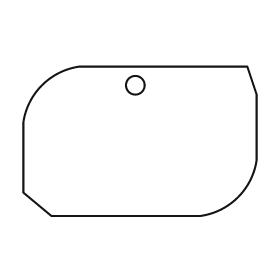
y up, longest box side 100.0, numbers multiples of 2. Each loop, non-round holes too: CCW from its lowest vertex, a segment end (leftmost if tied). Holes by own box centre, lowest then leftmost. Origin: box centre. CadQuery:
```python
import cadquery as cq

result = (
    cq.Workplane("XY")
    .moveTo(-38.0, -32.0)
    .lineTo(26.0, -32.0)
    .threePointArc((42.0, -24.0), (50.0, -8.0))
    .lineTo(50.0, 20.0)
    .lineTo(46.0, 32.0)
    .lineTo(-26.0, 32.0)
    .threePointArc((-42.0, 24.0), (-50.0, 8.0))
    .lineTo(-50.0, -22.0)
    .close()
    .moveTo(-2.0, 24.0)
    .circle(4.0)
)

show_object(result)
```